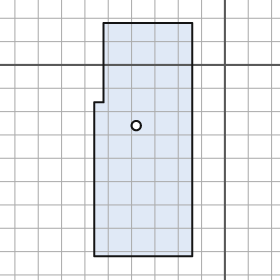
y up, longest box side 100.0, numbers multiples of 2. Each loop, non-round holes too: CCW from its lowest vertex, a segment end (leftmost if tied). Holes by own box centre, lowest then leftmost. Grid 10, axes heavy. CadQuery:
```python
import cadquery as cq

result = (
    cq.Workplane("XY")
    .moveTo(-56.0, -82.0)
    .lineTo(-14.0, -82.0)
    .lineTo(-14.0, 18.0)
    .lineTo(-52.0, 18.0)
    .lineTo(-52.0, -16.0)
    .lineTo(-56.0, -16.0)
    .close()
    .moveTo(-38.0, -26.0)
    .circle(2.0)
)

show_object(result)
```